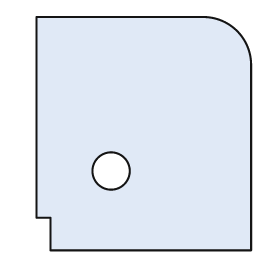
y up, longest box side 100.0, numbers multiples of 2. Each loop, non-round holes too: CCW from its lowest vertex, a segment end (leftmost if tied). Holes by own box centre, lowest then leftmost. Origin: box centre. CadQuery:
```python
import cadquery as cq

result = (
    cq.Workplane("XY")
    .moveTo(-40.0, -50.0)
    .lineTo(46.0, -50.0)
    .lineTo(46.0, 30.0)
    .threePointArc((40.0, 44.0), (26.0, 50.0))
    .lineTo(-46.0, 50.0)
    .lineTo(-46.0, -36.0)
    .lineTo(-40.0, -36.0)
    .close()
    .moveTo(-14.0, -16.0)
    .circle(8.0)
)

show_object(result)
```